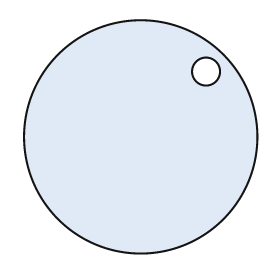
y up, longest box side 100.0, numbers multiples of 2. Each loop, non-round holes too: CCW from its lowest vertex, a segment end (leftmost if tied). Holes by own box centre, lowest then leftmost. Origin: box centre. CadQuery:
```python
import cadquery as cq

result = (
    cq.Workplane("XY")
    .moveTo(0.0, 0.0)
    .circle(50.0)
    .moveTo(28.0, 28.0)
    .circle(6.0)
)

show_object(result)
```